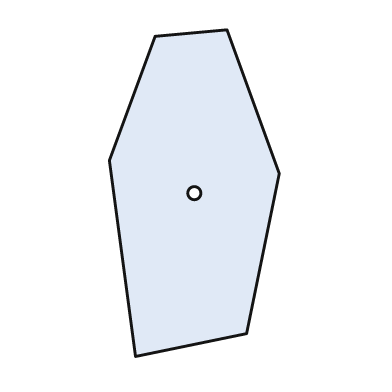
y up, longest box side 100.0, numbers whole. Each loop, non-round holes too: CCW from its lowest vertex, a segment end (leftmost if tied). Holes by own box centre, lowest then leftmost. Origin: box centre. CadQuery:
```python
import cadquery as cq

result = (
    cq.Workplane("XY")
    .moveTo(-18.0, -50.0)
    .lineTo(16.0, -43.0)
    .lineTo(26.0, 6.0)
    .lineTo(10.0, 50.0)
    .lineTo(-12.0, 48.0)
    .lineTo(-26.0, 10.0)
    .close()
    .moveTo(0.0, 0.0)
    .circle(2.0)
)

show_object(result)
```